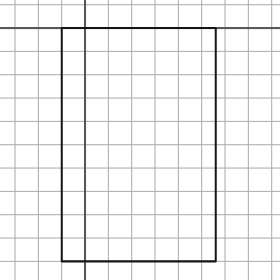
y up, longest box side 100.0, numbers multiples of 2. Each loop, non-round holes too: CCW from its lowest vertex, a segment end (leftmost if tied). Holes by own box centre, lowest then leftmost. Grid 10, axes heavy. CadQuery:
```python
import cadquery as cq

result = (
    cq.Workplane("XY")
    .moveTo(-10.0, -100.0)
    .lineTo(56.0, -100.0)
    .lineTo(56.0, 0.0)
    .lineTo(-10.0, 0.0)
    .close()
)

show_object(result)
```